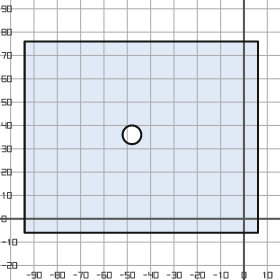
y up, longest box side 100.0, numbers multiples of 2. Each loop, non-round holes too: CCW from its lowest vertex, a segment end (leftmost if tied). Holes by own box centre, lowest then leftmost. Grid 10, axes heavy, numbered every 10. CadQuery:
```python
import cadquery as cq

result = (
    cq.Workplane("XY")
    .moveTo(-94.0, -6.0)
    .lineTo(6.0, -6.0)
    .lineTo(6.0, 76.0)
    .lineTo(-94.0, 76.0)
    .close()
    .moveTo(-48.0, 36.0)
    .circle(4.0)
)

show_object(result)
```